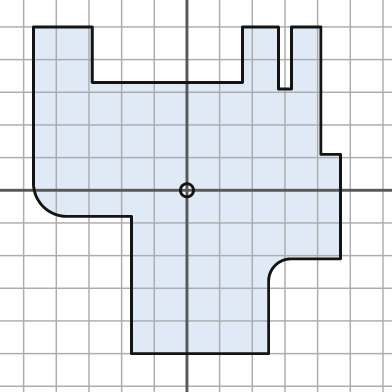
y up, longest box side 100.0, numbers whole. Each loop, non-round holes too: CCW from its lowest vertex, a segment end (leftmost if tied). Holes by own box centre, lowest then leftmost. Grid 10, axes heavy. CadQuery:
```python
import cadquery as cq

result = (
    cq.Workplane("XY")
    .moveTo(-17.0, -50.0)
    .lineTo(25.0, -50.0)
    .lineTo(25.0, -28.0)
    .threePointArc((27.0, -23.0), (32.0, -21.0))
    .lineTo(47.0, -21.0)
    .lineTo(47.0, 11.0)
    .lineTo(41.0, 11.0)
    .lineTo(41.0, 50.0)
    .lineTo(32.0, 50.0)
    .lineTo(32.0, 31.0)
    .lineTo(28.0, 31.0)
    .lineTo(28.0, 50.0)
    .lineTo(17.0, 50.0)
    .lineTo(17.0, 33.0)
    .lineTo(-29.0, 33.0)
    .lineTo(-29.0, 50.0)
    .lineTo(-47.0, 50.0)
    .lineTo(-47.0, 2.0)
    .threePointArc((-44.0, -5.0), (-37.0, -8.0))
    .lineTo(-17.0, -8.0)
    .close()
    .moveTo(0.0, 0.0)
    .circle(2.0)
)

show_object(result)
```